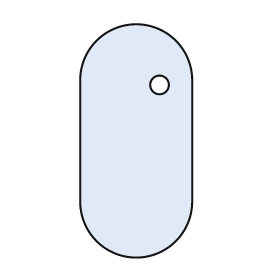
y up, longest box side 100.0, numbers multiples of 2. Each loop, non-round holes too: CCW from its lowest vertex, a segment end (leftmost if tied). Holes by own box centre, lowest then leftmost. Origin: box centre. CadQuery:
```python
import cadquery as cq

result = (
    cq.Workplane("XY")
    .moveTo(-24.0, -26.0)
    .threePointArc((0.0, -50.0), (24.0, -26.0))
    .lineTo(24.0, 26.0)
    .threePointArc((0.0, 50.0), (-24.0, 26.0))
    .close()
    .moveTo(10.0, 24.0)
    .circle(4.0)
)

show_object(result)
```